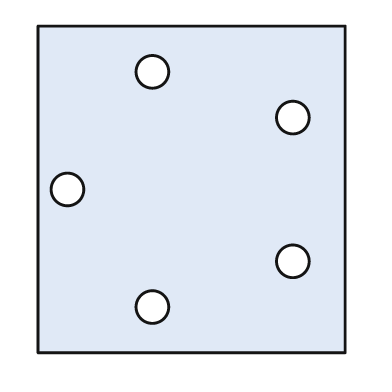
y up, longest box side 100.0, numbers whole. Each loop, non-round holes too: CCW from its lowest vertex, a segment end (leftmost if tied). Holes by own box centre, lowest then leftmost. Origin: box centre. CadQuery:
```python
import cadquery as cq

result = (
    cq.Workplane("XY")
    .moveTo(-47.0, -50.0)
    .lineTo(47.0, -50.0)
    .lineTo(47.0, 50.0)
    .lineTo(-47.0, 50.0)
    .close()
    .moveTo(-12.0, -36.0)
    .circle(5.0)
    .moveTo(31.0, -22.0)
    .circle(5.0)
    .moveTo(-38.0, 0.0)
    .circle(5.0)
    .moveTo(31.0, 22.0)
    .circle(5.0)
    .moveTo(-12.0, 36.0)
    .circle(5.0)
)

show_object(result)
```